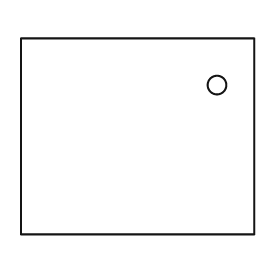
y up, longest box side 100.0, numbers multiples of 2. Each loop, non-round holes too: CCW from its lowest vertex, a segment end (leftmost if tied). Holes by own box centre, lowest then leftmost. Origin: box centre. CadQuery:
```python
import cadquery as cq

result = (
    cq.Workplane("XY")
    .moveTo(-50.0, -42.0)
    .lineTo(50.0, -42.0)
    .lineTo(50.0, 42.0)
    .lineTo(-50.0, 42.0)
    .close()
    .moveTo(34.0, 22.0)
    .circle(4.0)
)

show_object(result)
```